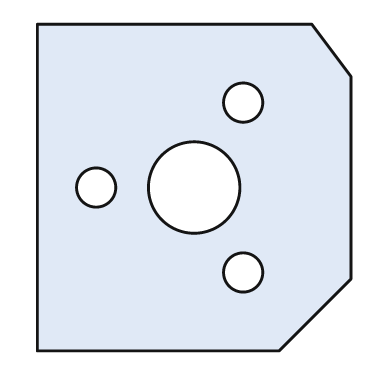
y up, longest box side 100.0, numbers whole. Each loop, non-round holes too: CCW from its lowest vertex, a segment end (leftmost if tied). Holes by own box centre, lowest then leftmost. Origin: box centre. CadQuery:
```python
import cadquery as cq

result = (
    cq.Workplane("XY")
    .moveTo(-48.0, -50.0)
    .lineTo(26.0, -50.0)
    .lineTo(48.0, -28.0)
    .lineTo(48.0, 34.0)
    .lineTo(36.0, 50.0)
    .lineTo(-48.0, 50.0)
    .close()
    .moveTo(15.0, -26.0)
    .circle(6.0)
    .moveTo(-30.0, 0.0)
    .circle(6.0)
    .moveTo(0.0, 0.0)
    .circle(14.0)
    .moveTo(15.0, 26.0)
    .circle(6.0)
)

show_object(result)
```